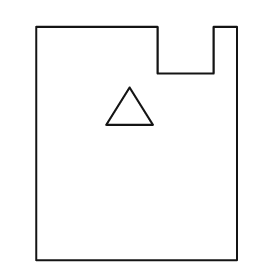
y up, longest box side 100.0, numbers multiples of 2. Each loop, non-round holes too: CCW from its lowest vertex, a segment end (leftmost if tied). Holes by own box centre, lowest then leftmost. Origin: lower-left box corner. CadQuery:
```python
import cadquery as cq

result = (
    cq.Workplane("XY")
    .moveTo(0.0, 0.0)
    .lineTo(86.0, 0.0)
    .lineTo(86.0, 100.0)
    .lineTo(76.0, 100.0)
    .lineTo(76.0, 80.0)
    .lineTo(52.0, 80.0)
    .lineTo(52.0, 100.0)
    .lineTo(0.0, 100.0)
    .close()
    .moveTo(30.0, 58.0)
    .lineTo(50.0, 58.0)
    .lineTo(40.0, 74.0)
    .close()
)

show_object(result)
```